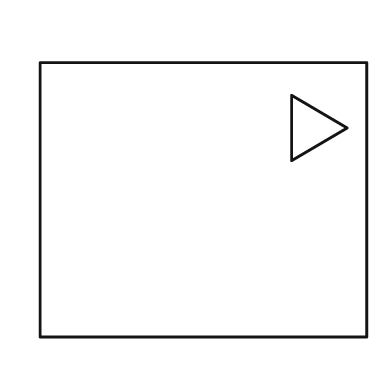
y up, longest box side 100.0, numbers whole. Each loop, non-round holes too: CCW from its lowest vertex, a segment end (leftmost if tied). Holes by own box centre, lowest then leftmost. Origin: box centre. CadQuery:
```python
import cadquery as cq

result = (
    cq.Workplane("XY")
    .moveTo(-50.0, -42.0)
    .lineTo(50.0, -42.0)
    .lineTo(50.0, 42.0)
    .lineTo(-50.0, 42.0)
    .close()
    .moveTo(27.0, 12.0)
    .lineTo(44.0, 22.0)
    .lineTo(27.0, 32.0)
    .close()
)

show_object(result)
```